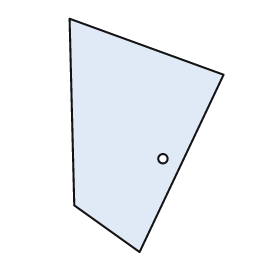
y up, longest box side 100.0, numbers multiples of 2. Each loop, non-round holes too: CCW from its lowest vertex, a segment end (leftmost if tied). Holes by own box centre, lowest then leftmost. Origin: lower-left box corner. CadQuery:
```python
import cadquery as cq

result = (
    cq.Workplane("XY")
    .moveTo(30.0, 0.0)
    .lineTo(66.0, 76.0)
    .lineTo(0.0, 100.0)
    .lineTo(2.0, 20.0)
    .close()
    .moveTo(40.0, 40.0)
    .circle(2.0)
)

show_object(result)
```